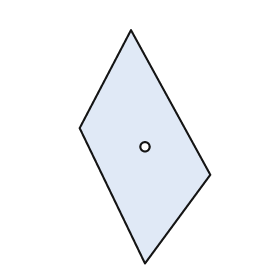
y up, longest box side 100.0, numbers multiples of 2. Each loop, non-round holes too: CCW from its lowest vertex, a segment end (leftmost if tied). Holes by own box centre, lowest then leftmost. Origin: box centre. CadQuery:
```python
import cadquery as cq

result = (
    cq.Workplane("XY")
    .moveTo(0.0, -50.0)
    .lineTo(28.0, -12.0)
    .lineTo(-6.0, 50.0)
    .lineTo(-28.0, 8.0)
    .close()
    .moveTo(0.0, 0.0)
    .circle(2.0)
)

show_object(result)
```